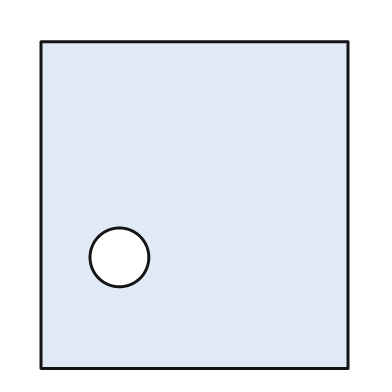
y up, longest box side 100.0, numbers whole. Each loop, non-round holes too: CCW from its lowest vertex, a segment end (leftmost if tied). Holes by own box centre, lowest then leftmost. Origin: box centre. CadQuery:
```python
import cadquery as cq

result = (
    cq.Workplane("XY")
    .moveTo(-47.0, -50.0)
    .lineTo(47.0, -50.0)
    .lineTo(47.0, 50.0)
    .lineTo(-47.0, 50.0)
    .close()
    .moveTo(-23.0, -16.0)
    .circle(9.0)
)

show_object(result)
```